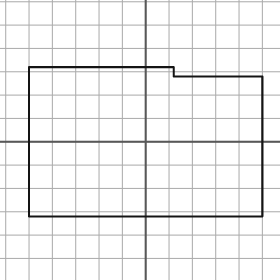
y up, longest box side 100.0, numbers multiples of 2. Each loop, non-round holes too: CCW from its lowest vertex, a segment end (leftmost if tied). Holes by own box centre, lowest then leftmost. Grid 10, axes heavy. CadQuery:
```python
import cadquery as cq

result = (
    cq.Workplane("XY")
    .moveTo(-50.0, -32.0)
    .lineTo(50.0, -32.0)
    .lineTo(50.0, 28.0)
    .lineTo(12.0, 28.0)
    .lineTo(12.0, 32.0)
    .lineTo(-50.0, 32.0)
    .close()
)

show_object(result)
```